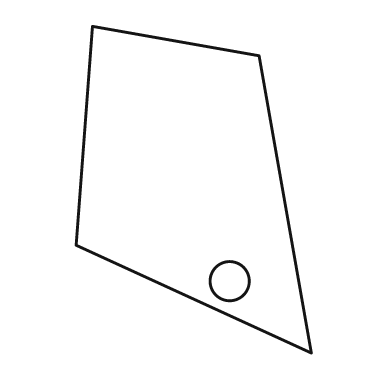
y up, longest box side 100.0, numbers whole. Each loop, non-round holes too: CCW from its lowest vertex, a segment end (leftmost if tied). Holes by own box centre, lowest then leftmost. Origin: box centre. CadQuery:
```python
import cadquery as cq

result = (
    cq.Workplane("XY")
    .moveTo(36.0, -50.0)
    .lineTo(20.0, 41.0)
    .lineTo(-31.0, 50.0)
    .lineTo(-36.0, -17.0)
    .close()
    .moveTo(11.0, -28.0)
    .circle(6.0)
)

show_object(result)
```